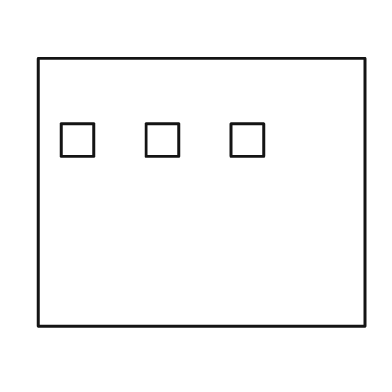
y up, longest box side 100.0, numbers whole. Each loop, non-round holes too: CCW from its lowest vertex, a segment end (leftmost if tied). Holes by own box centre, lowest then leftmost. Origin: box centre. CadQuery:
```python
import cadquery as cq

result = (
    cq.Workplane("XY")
    .moveTo(-50.0, -41.0)
    .lineTo(50.0, -41.0)
    .lineTo(50.0, 41.0)
    .lineTo(-50.0, 41.0)
    .close()
    .moveTo(-43.0, 11.0)
    .lineTo(-33.0, 11.0)
    .lineTo(-33.0, 21.0)
    .lineTo(-43.0, 21.0)
    .close()
    .moveTo(-17.0, 11.0)
    .lineTo(-7.0, 11.0)
    .lineTo(-7.0, 21.0)
    .lineTo(-17.0, 21.0)
    .close()
    .moveTo(9.0, 11.0)
    .lineTo(19.0, 11.0)
    .lineTo(19.0, 21.0)
    .lineTo(9.0, 21.0)
    .close()
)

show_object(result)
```